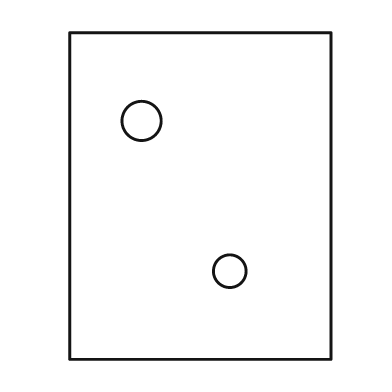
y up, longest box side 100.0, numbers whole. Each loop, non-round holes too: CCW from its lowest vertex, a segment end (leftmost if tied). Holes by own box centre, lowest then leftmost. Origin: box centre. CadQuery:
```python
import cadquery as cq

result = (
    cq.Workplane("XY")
    .moveTo(-40.0, -50.0)
    .lineTo(40.0, -50.0)
    .lineTo(40.0, 50.0)
    .lineTo(-40.0, 50.0)
    .close()
    .moveTo(9.0, -23.0)
    .circle(5.0)
    .moveTo(-18.0, 23.0)
    .circle(6.0)
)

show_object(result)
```